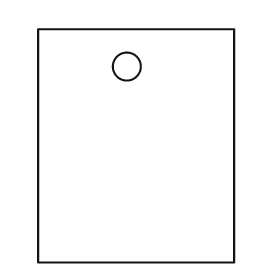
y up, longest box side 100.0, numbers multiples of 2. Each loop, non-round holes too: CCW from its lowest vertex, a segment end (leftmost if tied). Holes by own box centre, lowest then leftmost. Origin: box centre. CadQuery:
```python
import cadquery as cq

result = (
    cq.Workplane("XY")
    .moveTo(-42.0, -50.0)
    .lineTo(42.0, -50.0)
    .lineTo(42.0, 50.0)
    .lineTo(-42.0, 50.0)
    .close()
    .moveTo(-4.0, 34.0)
    .circle(6.0)
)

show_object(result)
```